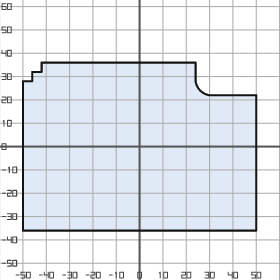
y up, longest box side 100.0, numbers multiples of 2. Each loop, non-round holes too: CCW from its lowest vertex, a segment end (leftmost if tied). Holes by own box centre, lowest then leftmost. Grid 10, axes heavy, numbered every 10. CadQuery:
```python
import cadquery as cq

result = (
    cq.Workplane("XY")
    .moveTo(-50.0, -36.0)
    .lineTo(50.0, -36.0)
    .lineTo(50.0, 22.0)
    .lineTo(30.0, 22.0)
    .threePointArc((26.0, 24.0), (24.0, 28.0))
    .lineTo(24.0, 36.0)
    .lineTo(-42.0, 36.0)
    .lineTo(-42.0, 32.0)
    .lineTo(-46.0, 32.0)
    .lineTo(-46.0, 28.0)
    .lineTo(-50.0, 28.0)
    .close()
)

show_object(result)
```